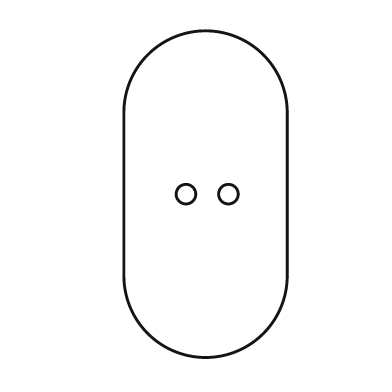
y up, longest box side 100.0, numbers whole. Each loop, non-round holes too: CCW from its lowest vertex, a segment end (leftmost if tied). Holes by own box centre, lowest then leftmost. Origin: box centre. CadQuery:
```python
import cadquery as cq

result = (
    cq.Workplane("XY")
    .moveTo(-25.0, -25.0)
    .threePointArc((0.0, -50.0), (25.0, -25.0))
    .lineTo(25.0, 25.0)
    .threePointArc((0.0, 50.0), (-25.0, 25.0))
    .close()
    .moveTo(-6.0, 0.0)
    .circle(3.0)
    .moveTo(7.0, 0.0)
    .circle(3.0)
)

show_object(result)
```